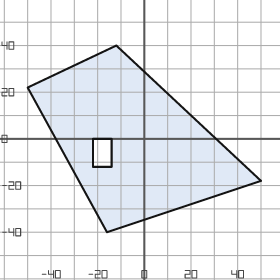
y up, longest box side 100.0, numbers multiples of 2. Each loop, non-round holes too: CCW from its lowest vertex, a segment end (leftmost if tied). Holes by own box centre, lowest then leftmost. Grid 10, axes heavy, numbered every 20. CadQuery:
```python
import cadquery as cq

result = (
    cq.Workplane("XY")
    .moveTo(-16.0, -40.0)
    .lineTo(50.0, -18.0)
    .lineTo(-12.0, 40.0)
    .lineTo(-50.0, 22.0)
    .close()
    .moveTo(-22.0, -12.0)
    .lineTo(-14.0, -12.0)
    .lineTo(-14.0, 0.0)
    .lineTo(-22.0, 0.0)
    .close()
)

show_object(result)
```